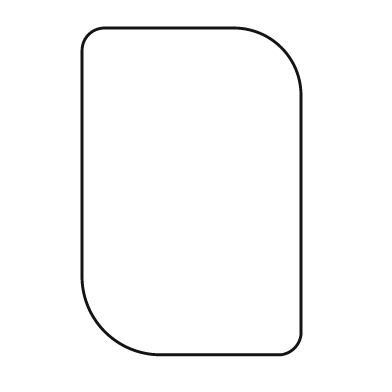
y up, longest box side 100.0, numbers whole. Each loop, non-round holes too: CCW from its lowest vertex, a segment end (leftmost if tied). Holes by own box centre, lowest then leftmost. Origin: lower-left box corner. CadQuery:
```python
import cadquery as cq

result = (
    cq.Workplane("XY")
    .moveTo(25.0, 0.0)
    .lineTo(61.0, 0.0)
    .threePointArc((65.0, 2.0), (67.0, 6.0))
    .lineTo(67.0, 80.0)
    .threePointArc((61.0, 94.0), (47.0, 100.0))
    .lineTo(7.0, 100.0)
    .threePointArc((2.0, 98.0), (0.0, 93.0))
    .lineTo(0.0, 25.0)
    .threePointArc((7.0, 7.0), (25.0, 0.0))
    .close()
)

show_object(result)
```